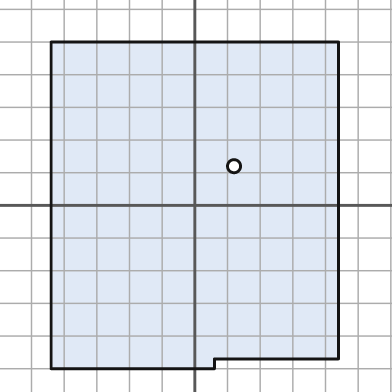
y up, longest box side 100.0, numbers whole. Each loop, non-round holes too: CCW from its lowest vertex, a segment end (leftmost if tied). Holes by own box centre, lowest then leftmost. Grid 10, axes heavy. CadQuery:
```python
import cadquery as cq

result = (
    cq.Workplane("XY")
    .moveTo(-44.0, -50.0)
    .lineTo(6.0, -50.0)
    .lineTo(6.0, -47.0)
    .lineTo(44.0, -47.0)
    .lineTo(44.0, 50.0)
    .lineTo(-44.0, 50.0)
    .close()
    .moveTo(12.0, 12.0)
    .circle(2.0)
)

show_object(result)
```